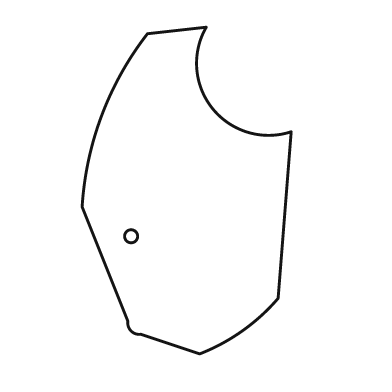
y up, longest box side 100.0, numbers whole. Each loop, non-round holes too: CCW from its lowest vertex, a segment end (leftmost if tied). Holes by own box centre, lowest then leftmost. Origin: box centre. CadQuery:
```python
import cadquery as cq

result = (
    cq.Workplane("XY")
    .moveTo(4.0, -50.0)
    .threePointArc((17.0, -43.0), (28.0, -33.0))
    .lineTo(32.0, 18.0)
    .threePointArc((8.0, 25.0), (6.0, 50.0))
    .lineTo(-12.0, 48.0)
    .threePointArc((-26.0, 23.0), (-32.0, -5.0))
    .lineTo(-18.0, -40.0)
    .threePointArc((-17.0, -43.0), (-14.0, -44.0))
    .close()
    .moveTo(-17.0, -14.0)
    .circle(2.0)
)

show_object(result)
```